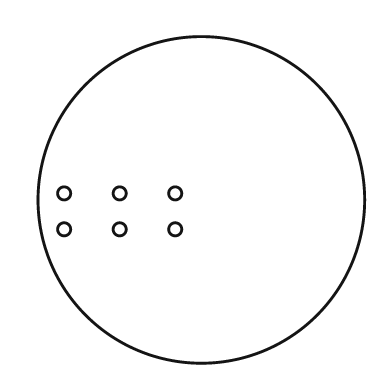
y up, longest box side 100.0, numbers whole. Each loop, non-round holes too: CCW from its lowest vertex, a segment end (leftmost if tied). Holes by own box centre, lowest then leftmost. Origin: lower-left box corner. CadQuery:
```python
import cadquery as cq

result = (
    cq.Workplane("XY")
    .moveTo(50.0, 50.0)
    .circle(50.0)
    .moveTo(8.0, 41.0)
    .circle(2.0)
    .moveTo(25.0, 41.0)
    .circle(2.0)
    .moveTo(42.0, 41.0)
    .circle(2.0)
    .moveTo(8.0, 52.0)
    .circle(2.0)
    .moveTo(25.0, 52.0)
    .circle(2.0)
    .moveTo(42.0, 52.0)
    .circle(2.0)
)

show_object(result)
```